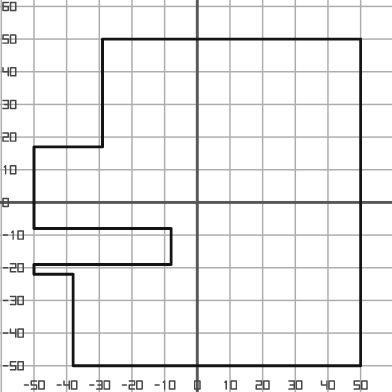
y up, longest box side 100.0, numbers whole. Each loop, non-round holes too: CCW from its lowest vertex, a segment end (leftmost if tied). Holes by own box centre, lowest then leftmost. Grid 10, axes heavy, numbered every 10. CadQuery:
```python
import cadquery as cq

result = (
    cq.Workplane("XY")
    .moveTo(-38.0, -50.0)
    .lineTo(50.0, -50.0)
    .lineTo(50.0, 50.0)
    .lineTo(-29.0, 50.0)
    .lineTo(-29.0, 17.0)
    .lineTo(-50.0, 17.0)
    .lineTo(-50.0, -8.0)
    .lineTo(-8.0, -8.0)
    .lineTo(-8.0, -19.0)
    .lineTo(-50.0, -19.0)
    .lineTo(-50.0, -22.0)
    .lineTo(-38.0, -22.0)
    .close()
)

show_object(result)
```